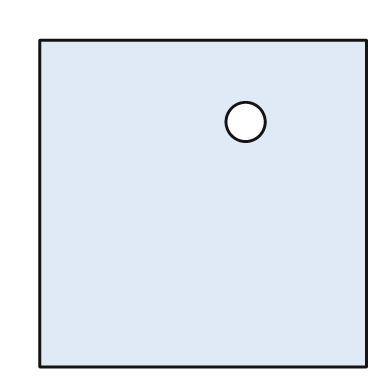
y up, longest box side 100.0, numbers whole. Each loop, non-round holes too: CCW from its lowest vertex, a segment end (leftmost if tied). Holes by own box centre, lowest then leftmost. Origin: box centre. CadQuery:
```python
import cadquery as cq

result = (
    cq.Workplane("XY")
    .moveTo(-50.0, -50.0)
    .lineTo(50.0, -50.0)
    .lineTo(50.0, 50.0)
    .lineTo(-50.0, 50.0)
    .close()
    .moveTo(13.0, 25.0)
    .circle(6.0)
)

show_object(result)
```